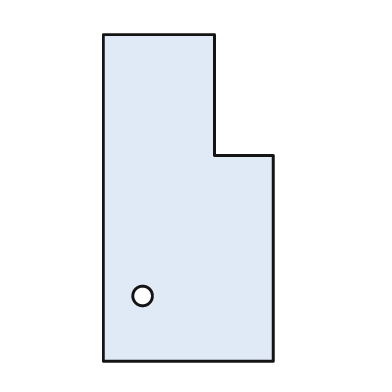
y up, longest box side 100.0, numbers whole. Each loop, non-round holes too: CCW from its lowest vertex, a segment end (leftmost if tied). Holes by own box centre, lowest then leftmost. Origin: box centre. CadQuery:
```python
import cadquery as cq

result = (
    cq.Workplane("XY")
    .moveTo(-26.0, -50.0)
    .lineTo(26.0, -50.0)
    .lineTo(26.0, 13.0)
    .lineTo(8.0, 13.0)
    .lineTo(8.0, 50.0)
    .lineTo(-26.0, 50.0)
    .close()
    .moveTo(-14.0, -30.0)
    .circle(3.0)
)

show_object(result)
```